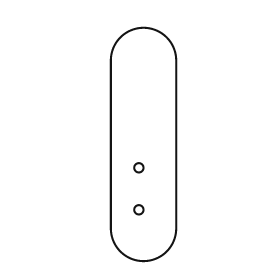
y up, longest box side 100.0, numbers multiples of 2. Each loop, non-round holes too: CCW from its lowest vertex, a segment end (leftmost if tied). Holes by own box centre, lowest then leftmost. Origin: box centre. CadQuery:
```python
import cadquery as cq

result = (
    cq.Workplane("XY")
    .moveTo(-14.0, -36.0)
    .threePointArc((0.0, -50.0), (14.0, -36.0))
    .lineTo(14.0, 36.0)
    .threePointArc((0.0, 50.0), (-14.0, 36.0))
    .close()
    .moveTo(-2.0, -28.0)
    .circle(2.0)
    .moveTo(-2.0, -10.0)
    .circle(2.0)
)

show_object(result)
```